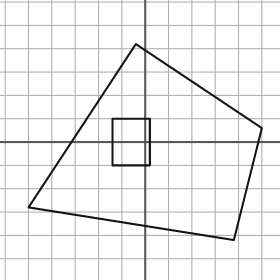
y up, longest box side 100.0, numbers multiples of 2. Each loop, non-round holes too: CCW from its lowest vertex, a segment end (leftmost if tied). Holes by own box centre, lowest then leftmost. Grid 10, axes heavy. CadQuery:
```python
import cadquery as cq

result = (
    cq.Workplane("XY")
    .moveTo(38.0, -42.0)
    .lineTo(50.0, 6.0)
    .lineTo(-4.0, 42.0)
    .lineTo(-50.0, -28.0)
    .close()
    .moveTo(-14.0, -10.0)
    .lineTo(2.0, -10.0)
    .lineTo(2.0, 10.0)
    .lineTo(-14.0, 10.0)
    .close()
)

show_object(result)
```